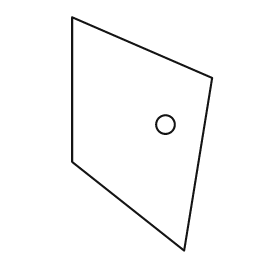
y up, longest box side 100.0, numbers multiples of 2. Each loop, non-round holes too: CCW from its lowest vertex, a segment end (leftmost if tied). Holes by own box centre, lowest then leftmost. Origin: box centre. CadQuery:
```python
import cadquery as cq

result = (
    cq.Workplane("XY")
    .moveTo(18.0, -50.0)
    .lineTo(30.0, 24.0)
    .lineTo(-30.0, 50.0)
    .lineTo(-30.0, -12.0)
    .close()
    .moveTo(10.0, 4.0)
    .circle(4.0)
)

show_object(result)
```